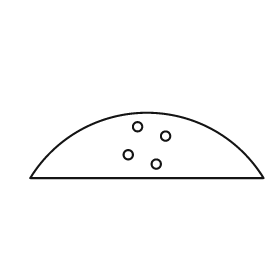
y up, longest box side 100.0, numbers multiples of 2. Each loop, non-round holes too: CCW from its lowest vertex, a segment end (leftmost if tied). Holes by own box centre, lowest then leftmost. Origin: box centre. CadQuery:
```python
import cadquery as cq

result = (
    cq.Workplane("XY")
    .moveTo(-50.0, -14.0)
    .lineTo(50.0, -14.0)
    .threePointArc((0.0, 14.0), (-50.0, -14.0))
    .close()
    .moveTo(4.0, -8.0)
    .circle(2.0)
    .moveTo(-8.0, -4.0)
    .circle(2.0)
    .moveTo(8.0, 4.0)
    .circle(2.0)
    .moveTo(-4.0, 8.0)
    .circle(2.0)
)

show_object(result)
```